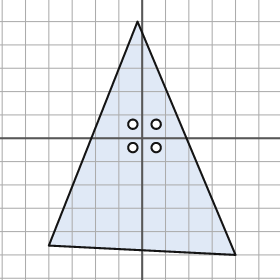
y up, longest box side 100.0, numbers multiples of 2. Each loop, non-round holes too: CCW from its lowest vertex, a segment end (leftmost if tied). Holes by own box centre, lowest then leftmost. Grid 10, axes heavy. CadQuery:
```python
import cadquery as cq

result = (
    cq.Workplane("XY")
    .moveTo(40.0, -50.0)
    .lineTo(-2.0, 50.0)
    .lineTo(-40.0, -46.0)
    .close()
    .moveTo(-4.0, -4.0)
    .circle(2.0)
    .moveTo(6.0, -4.0)
    .circle(2.0)
    .moveTo(-4.0, 6.0)
    .circle(2.0)
    .moveTo(6.0, 6.0)
    .circle(2.0)
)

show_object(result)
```